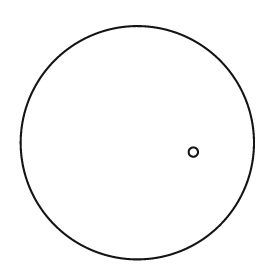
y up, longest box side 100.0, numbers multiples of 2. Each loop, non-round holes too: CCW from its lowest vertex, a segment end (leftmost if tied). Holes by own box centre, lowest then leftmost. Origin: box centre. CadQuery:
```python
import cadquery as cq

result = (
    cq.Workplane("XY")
    .moveTo(0.0, 0.0)
    .circle(50.0)
    .moveTo(24.0, -4.0)
    .circle(2.0)
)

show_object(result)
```